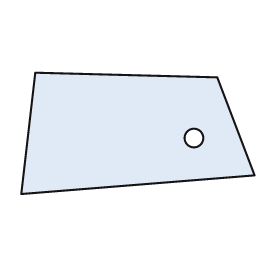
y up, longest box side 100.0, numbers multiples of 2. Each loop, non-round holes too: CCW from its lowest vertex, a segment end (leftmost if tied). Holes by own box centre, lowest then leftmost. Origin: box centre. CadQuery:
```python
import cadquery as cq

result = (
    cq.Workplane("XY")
    .moveTo(-50.0, -26.0)
    .lineTo(50.0, -18.0)
    .lineTo(34.0, 24.0)
    .lineTo(-44.0, 26.0)
    .close()
    .moveTo(24.0, -2.0)
    .circle(4.0)
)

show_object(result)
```